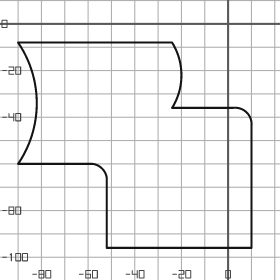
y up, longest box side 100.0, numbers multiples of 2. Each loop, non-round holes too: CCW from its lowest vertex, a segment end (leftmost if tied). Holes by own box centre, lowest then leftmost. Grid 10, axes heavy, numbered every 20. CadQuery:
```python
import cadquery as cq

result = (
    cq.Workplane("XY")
    .moveTo(-52.0, -96.0)
    .lineTo(10.0, -96.0)
    .lineTo(10.0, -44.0)
    .threePointArc((8.0, -38.0), (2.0, -36.0))
    .lineTo(-24.0, -36.0)
    .threePointArc((-20.0, -22.0), (-24.0, -8.0))
    .lineTo(-90.0, -8.0)
    .threePointArc((-82.0, -34.0), (-90.0, -60.0))
    .lineTo(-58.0, -60.0)
    .threePointArc((-54.0, -62.0), (-52.0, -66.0))
    .close()
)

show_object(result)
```